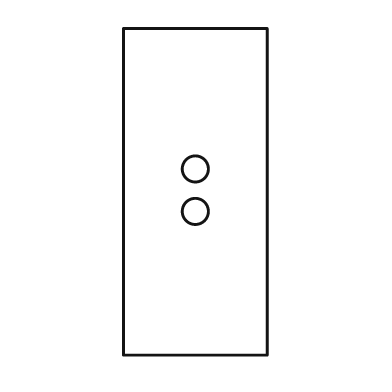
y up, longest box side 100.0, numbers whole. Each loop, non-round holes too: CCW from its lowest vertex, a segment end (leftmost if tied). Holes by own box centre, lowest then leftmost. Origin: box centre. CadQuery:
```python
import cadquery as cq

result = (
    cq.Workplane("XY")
    .moveTo(-22.0, -50.0)
    .lineTo(22.0, -50.0)
    .lineTo(22.0, 50.0)
    .lineTo(-22.0, 50.0)
    .close()
    .moveTo(0.0, -6.0)
    .circle(4.0)
    .moveTo(0.0, 7.0)
    .circle(4.0)
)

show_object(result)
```